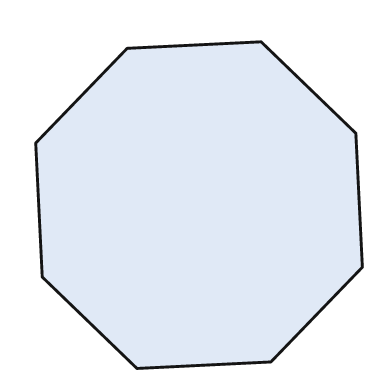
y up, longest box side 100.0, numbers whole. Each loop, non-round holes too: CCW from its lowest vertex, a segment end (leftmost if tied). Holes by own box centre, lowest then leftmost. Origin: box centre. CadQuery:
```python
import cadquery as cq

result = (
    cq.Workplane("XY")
    .moveTo(-19.0, -50.0)
    .lineTo(22.0, -48.0)
    .lineTo(50.0, -19.0)
    .lineTo(48.0, 22.0)
    .lineTo(19.0, 50.0)
    .lineTo(-22.0, 48.0)
    .lineTo(-50.0, 19.0)
    .lineTo(-48.0, -22.0)
    .close()
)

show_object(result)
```